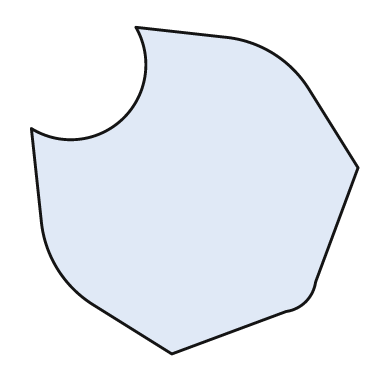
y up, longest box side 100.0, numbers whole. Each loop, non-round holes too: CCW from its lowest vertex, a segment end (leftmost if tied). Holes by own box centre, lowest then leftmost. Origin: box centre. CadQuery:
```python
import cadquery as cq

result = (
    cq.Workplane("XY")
    .moveTo(-7.0, -50.0)
    .lineTo(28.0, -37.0)
    .threePointArc((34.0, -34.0), (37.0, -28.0))
    .lineTo(50.0, 7.0)
    .lineTo(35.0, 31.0)
    .threePointArc((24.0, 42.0), (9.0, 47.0))
    .lineTo(-18.0, 50.0)
    .threePointArc((-22.0, 22.0), (-50.0, 19.0))
    .lineTo(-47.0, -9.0)
    .threePointArc((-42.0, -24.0), (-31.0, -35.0))
    .close()
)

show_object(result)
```